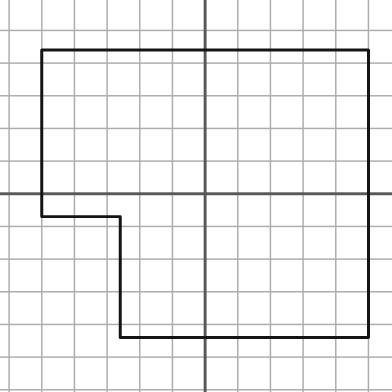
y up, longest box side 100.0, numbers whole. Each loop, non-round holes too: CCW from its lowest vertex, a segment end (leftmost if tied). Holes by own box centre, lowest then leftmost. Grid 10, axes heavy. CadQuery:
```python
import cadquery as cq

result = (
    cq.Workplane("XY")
    .moveTo(-26.0, -44.0)
    .lineTo(50.0, -44.0)
    .lineTo(50.0, 44.0)
    .lineTo(-50.0, 44.0)
    .lineTo(-50.0, -7.0)
    .lineTo(-26.0, -7.0)
    .close()
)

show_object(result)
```